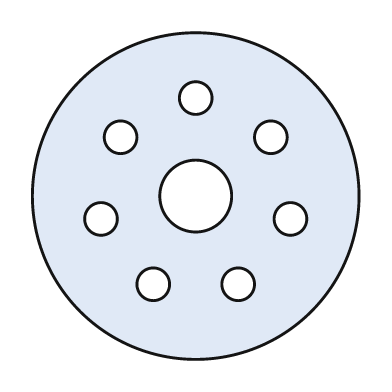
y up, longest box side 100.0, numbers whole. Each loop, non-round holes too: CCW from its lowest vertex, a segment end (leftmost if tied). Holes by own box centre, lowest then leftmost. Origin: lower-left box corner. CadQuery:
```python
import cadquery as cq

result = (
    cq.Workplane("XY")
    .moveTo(50.0, 50.0)
    .circle(50.0)
    .moveTo(37.0, 23.0)
    .circle(5.0)
    .moveTo(63.0, 23.0)
    .circle(5.0)
    .moveTo(21.0, 43.0)
    .circle(5.0)
    .moveTo(79.0, 43.0)
    .circle(5.0)
    .moveTo(50.0, 50.0)
    .circle(11.0)
    .moveTo(27.0, 68.0)
    .circle(5.0)
    .moveTo(73.0, 68.0)
    .circle(5.0)
    .moveTo(50.0, 80.0)
    .circle(5.0)
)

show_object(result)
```